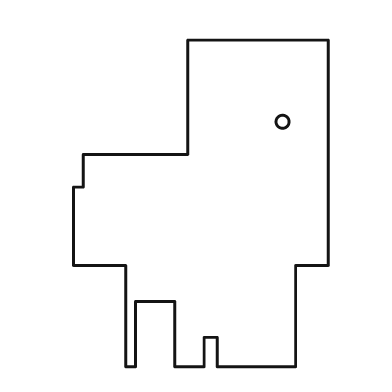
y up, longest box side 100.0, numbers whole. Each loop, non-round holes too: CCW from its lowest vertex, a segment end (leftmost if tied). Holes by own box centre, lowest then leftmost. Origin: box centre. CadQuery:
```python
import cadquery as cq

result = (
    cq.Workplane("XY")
    .moveTo(-23.0, -50.0)
    .lineTo(-20.0, -50.0)
    .lineTo(-20.0, -30.0)
    .lineTo(-8.0, -30.0)
    .lineTo(-8.0, -50.0)
    .lineTo(1.0, -50.0)
    .lineTo(1.0, -41.0)
    .lineTo(5.0, -41.0)
    .lineTo(5.0, -50.0)
    .lineTo(29.0, -50.0)
    .lineTo(29.0, -19.0)
    .lineTo(39.0, -19.0)
    .lineTo(39.0, 50.0)
    .lineTo(-4.0, 50.0)
    .lineTo(-4.0, 15.0)
    .lineTo(-36.0, 15.0)
    .lineTo(-36.0, 5.0)
    .lineTo(-39.0, 5.0)
    .lineTo(-39.0, -19.0)
    .lineTo(-23.0, -19.0)
    .close()
    .moveTo(25.0, 25.0)
    .circle(2.0)
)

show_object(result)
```